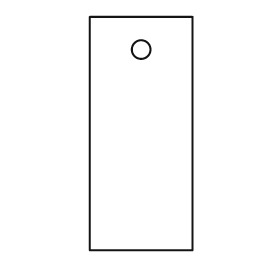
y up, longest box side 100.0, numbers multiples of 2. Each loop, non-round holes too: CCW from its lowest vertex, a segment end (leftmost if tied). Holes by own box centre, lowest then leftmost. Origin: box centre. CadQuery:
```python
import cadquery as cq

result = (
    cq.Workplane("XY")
    .moveTo(-22.0, -50.0)
    .lineTo(22.0, -50.0)
    .lineTo(22.0, 50.0)
    .lineTo(-22.0, 50.0)
    .close()
    .moveTo(0.0, 36.0)
    .circle(4.0)
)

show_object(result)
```